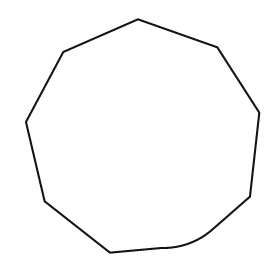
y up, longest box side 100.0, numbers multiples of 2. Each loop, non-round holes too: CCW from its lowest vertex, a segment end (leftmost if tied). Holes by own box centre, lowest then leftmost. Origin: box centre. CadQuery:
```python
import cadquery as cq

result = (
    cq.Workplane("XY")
    .moveTo(-14.0, -50.0)
    .lineTo(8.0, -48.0)
    .threePointArc((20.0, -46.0), (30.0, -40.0))
    .lineTo(46.0, -26.0)
    .lineTo(50.0, 10.0)
    .lineTo(32.0, 38.0)
    .lineTo(-2.0, 50.0)
    .lineTo(-34.0, 36.0)
    .lineTo(-50.0, 6.0)
    .lineTo(-42.0, -28.0)
    .close()
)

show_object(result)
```